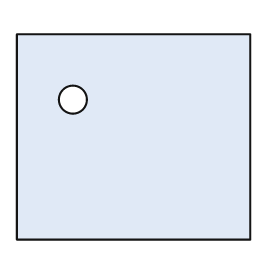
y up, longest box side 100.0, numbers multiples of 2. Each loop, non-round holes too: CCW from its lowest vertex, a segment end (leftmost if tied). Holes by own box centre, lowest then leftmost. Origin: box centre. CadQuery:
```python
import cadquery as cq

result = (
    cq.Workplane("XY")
    .moveTo(-50.0, -44.0)
    .lineTo(50.0, -44.0)
    .lineTo(50.0, 44.0)
    .lineTo(-50.0, 44.0)
    .close()
    .moveTo(-26.0, 16.0)
    .circle(6.0)
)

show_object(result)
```